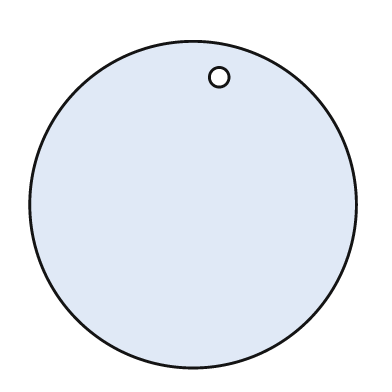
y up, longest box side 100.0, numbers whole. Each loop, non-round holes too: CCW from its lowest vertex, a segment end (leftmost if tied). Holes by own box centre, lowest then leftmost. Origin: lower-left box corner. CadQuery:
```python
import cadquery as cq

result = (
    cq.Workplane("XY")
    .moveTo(50.0, 50.0)
    .circle(50.0)
    .moveTo(58.0, 89.0)
    .circle(3.0)
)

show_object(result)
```